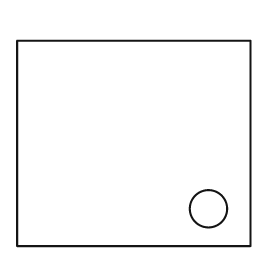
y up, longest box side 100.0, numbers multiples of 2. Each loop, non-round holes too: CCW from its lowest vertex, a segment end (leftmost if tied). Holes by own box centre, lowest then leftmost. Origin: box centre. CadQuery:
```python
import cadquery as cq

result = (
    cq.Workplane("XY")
    .moveTo(-50.0, -44.0)
    .lineTo(50.0, -44.0)
    .lineTo(50.0, 44.0)
    .lineTo(-50.0, 44.0)
    .close()
    .moveTo(32.0, -28.0)
    .circle(8.0)
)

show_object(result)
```